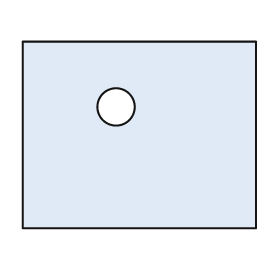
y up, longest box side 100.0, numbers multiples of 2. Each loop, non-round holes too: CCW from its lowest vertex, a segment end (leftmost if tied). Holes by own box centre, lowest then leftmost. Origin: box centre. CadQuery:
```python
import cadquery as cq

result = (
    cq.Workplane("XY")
    .moveTo(-50.0, -40.0)
    .lineTo(50.0, -40.0)
    .lineTo(50.0, 40.0)
    .lineTo(-50.0, 40.0)
    .close()
    .moveTo(-10.0, 12.0)
    .circle(8.0)
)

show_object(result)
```